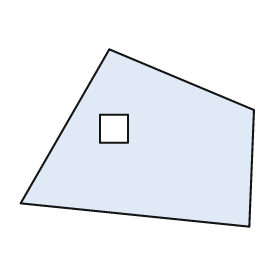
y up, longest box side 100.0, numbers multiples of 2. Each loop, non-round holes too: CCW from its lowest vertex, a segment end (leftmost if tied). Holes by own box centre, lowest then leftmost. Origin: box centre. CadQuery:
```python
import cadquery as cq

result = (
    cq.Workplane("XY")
    .moveTo(48.0, -38.0)
    .lineTo(50.0, 12.0)
    .lineTo(-12.0, 38.0)
    .lineTo(-50.0, -28.0)
    .close()
    .moveTo(-16.0, -2.0)
    .lineTo(-4.0, -2.0)
    .lineTo(-4.0, 10.0)
    .lineTo(-16.0, 10.0)
    .close()
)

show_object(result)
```